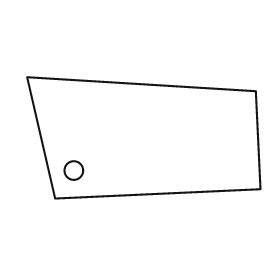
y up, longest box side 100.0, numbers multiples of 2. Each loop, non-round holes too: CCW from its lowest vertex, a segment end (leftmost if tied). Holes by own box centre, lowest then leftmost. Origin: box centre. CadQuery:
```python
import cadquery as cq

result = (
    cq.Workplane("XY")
    .moveTo(-38.0, -26.0)
    .lineTo(50.0, -22.0)
    .lineTo(48.0, 20.0)
    .lineTo(-50.0, 26.0)
    .close()
    .moveTo(-30.0, -14.0)
    .circle(4.0)
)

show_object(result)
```